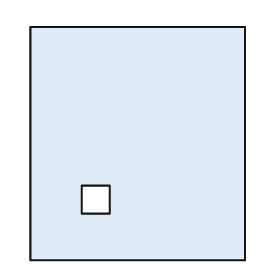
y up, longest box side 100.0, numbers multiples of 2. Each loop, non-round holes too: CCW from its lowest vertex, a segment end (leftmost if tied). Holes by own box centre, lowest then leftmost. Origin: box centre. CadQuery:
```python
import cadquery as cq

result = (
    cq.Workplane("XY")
    .moveTo(-46.0, -50.0)
    .lineTo(46.0, -50.0)
    .lineTo(46.0, 50.0)
    .lineTo(-46.0, 50.0)
    .close()
    .moveTo(-24.0, -30.0)
    .lineTo(-12.0, -30.0)
    .lineTo(-12.0, -18.0)
    .lineTo(-24.0, -18.0)
    .close()
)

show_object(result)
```